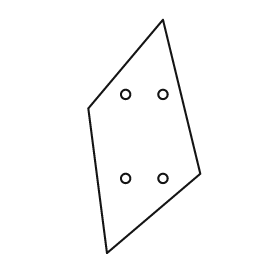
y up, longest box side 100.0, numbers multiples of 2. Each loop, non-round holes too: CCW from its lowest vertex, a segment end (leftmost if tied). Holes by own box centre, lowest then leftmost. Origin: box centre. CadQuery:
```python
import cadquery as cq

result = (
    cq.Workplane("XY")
    .moveTo(-16.0, -50.0)
    .lineTo(24.0, -16.0)
    .lineTo(8.0, 50.0)
    .lineTo(-24.0, 12.0)
    .close()
    .moveTo(-8.0, -18.0)
    .circle(2.0)
    .moveTo(8.0, -18.0)
    .circle(2.0)
    .moveTo(-8.0, 18.0)
    .circle(2.0)
    .moveTo(8.0, 18.0)
    .circle(2.0)
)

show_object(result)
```